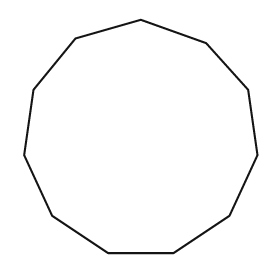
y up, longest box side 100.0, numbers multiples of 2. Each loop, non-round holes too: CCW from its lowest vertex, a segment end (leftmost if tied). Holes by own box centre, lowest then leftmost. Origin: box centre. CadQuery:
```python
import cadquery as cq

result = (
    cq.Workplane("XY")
    .moveTo(-14.0, -50.0)
    .lineTo(14.0, -50.0)
    .lineTo(38.0, -34.0)
    .lineTo(50.0, -8.0)
    .lineTo(46.0, 20.0)
    .lineTo(28.0, 40.0)
    .lineTo(0.0, 50.0)
    .lineTo(-28.0, 42.0)
    .lineTo(-46.0, 20.0)
    .lineTo(-50.0, -8.0)
    .lineTo(-38.0, -34.0)
    .close()
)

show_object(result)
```